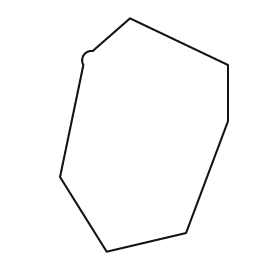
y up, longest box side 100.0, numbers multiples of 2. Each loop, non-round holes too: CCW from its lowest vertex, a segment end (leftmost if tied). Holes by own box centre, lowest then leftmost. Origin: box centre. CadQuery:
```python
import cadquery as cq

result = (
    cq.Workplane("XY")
    .moveTo(-16.0, -50.0)
    .lineTo(18.0, -42.0)
    .lineTo(36.0, 6.0)
    .lineTo(36.0, 30.0)
    .lineTo(-6.0, 50.0)
    .lineTo(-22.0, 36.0)
    .threePointArc((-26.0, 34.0), (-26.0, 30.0))
    .lineTo(-36.0, -18.0)
    .close()
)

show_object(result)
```